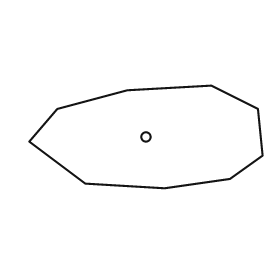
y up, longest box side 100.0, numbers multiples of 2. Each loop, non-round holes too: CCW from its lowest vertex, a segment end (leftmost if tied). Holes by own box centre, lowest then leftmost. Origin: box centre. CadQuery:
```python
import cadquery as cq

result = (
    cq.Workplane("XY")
    .moveTo(8.0, -22.0)
    .lineTo(36.0, -18.0)
    .lineTo(50.0, -8.0)
    .lineTo(48.0, 12.0)
    .lineTo(28.0, 22.0)
    .lineTo(-8.0, 20.0)
    .lineTo(-38.0, 12.0)
    .lineTo(-50.0, -2.0)
    .lineTo(-26.0, -20.0)
    .close()
    .moveTo(0.0, 0.0)
    .circle(2.0)
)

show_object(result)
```